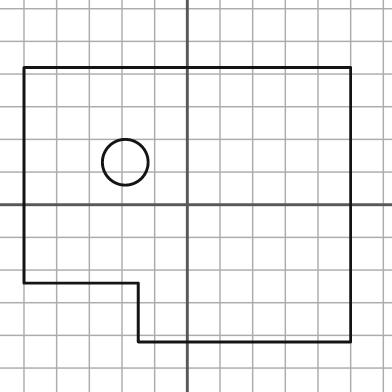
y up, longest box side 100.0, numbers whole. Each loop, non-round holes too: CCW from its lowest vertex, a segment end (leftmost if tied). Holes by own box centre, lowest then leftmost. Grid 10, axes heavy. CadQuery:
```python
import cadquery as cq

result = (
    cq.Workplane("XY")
    .moveTo(-15.0, -42.0)
    .lineTo(50.0, -42.0)
    .lineTo(50.0, 42.0)
    .lineTo(-50.0, 42.0)
    .lineTo(-50.0, -24.0)
    .lineTo(-15.0, -24.0)
    .close()
    .moveTo(-19.0, 13.0)
    .circle(7.0)
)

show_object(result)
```